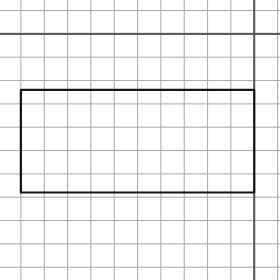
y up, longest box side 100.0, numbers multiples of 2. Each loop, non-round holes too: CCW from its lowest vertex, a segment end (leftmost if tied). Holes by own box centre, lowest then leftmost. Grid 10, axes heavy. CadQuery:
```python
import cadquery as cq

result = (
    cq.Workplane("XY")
    .moveTo(-100.0, -68.0)
    .lineTo(0.0, -68.0)
    .lineTo(0.0, -24.0)
    .lineTo(-100.0, -24.0)
    .close()
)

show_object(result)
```